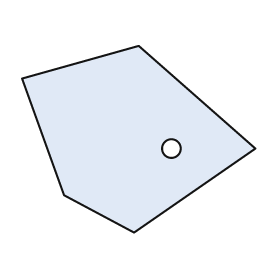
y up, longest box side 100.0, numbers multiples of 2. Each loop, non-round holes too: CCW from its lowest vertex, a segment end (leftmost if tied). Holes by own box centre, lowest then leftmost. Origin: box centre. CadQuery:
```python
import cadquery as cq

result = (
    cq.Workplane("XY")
    .moveTo(-2.0, -40.0)
    .lineTo(50.0, -4.0)
    .lineTo(0.0, 40.0)
    .lineTo(-50.0, 26.0)
    .lineTo(-32.0, -24.0)
    .close()
    .moveTo(14.0, -4.0)
    .circle(4.0)
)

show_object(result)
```